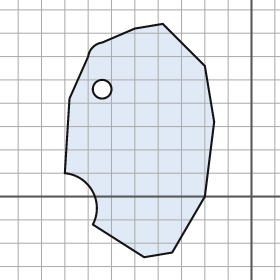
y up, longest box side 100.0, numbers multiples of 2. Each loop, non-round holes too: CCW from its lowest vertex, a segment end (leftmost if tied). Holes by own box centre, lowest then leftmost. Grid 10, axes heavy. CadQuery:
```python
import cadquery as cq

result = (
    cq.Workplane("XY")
    .moveTo(-46.0, -26.0)
    .lineTo(-34.0, -24.0)
    .lineTo(-20.0, 0.0)
    .lineTo(-16.0, 32.0)
    .lineTo(-20.0, 56.0)
    .lineTo(-38.0, 74.0)
    .lineTo(-50.0, 72.0)
    .lineTo(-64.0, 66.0)
    .threePointArc((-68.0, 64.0), (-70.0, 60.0))
    .lineTo(-78.0, 42.0)
    .lineTo(-80.0, 10.0)
    .threePointArc((-68.0, 2.0), (-68.0, -12.0))
    .close()
    .moveTo(-64.0, 46.0)
    .circle(4.0)
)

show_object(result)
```